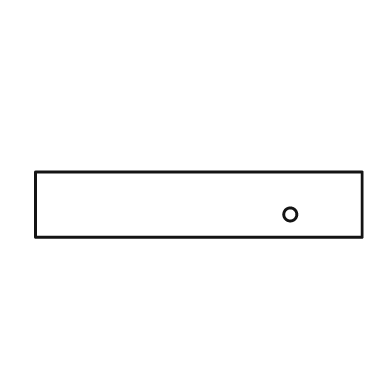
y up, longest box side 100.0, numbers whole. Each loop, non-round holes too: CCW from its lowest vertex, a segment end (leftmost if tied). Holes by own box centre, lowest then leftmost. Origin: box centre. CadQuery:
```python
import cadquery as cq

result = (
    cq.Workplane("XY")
    .moveTo(-50.0, -10.0)
    .lineTo(50.0, -10.0)
    .lineTo(50.0, 10.0)
    .lineTo(-50.0, 10.0)
    .close()
    .moveTo(28.0, -3.0)
    .circle(2.0)
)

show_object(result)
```